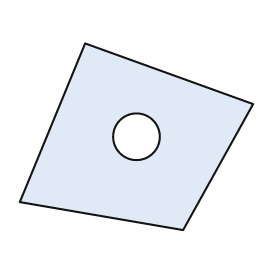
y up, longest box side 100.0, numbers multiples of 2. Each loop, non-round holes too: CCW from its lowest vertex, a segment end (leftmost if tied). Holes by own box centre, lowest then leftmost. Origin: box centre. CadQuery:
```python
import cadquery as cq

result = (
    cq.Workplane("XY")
    .moveTo(20.0, -40.0)
    .lineTo(50.0, 14.0)
    .lineTo(-22.0, 40.0)
    .lineTo(-50.0, -28.0)
    .close()
    .moveTo(0.0, 0.0)
    .circle(10.0)
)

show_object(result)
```